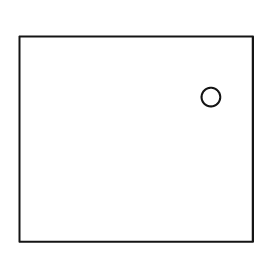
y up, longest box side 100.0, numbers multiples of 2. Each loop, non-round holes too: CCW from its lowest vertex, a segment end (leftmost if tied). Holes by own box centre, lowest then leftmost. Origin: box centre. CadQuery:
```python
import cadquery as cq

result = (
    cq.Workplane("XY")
    .moveTo(-50.0, -44.0)
    .lineTo(50.0, -44.0)
    .lineTo(50.0, 44.0)
    .lineTo(-50.0, 44.0)
    .close()
    .moveTo(32.0, 18.0)
    .circle(4.0)
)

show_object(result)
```